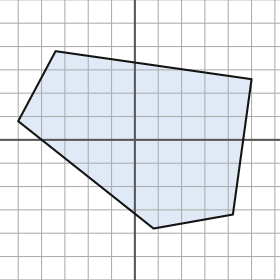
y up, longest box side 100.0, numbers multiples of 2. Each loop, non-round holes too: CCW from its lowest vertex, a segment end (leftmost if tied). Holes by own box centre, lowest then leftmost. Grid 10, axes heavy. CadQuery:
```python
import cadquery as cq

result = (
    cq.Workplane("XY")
    .moveTo(8.0, -38.0)
    .lineTo(42.0, -32.0)
    .lineTo(50.0, 26.0)
    .lineTo(-34.0, 38.0)
    .lineTo(-50.0, 8.0)
    .close()
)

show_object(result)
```